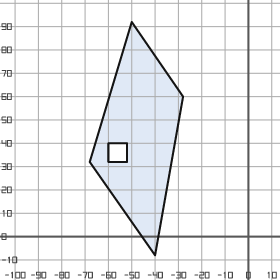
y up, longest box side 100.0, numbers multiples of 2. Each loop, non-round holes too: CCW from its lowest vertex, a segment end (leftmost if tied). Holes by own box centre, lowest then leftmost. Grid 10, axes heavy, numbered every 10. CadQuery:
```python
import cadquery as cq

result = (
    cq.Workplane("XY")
    .moveTo(-40.0, -8.0)
    .lineTo(-28.0, 60.0)
    .lineTo(-50.0, 92.0)
    .lineTo(-68.0, 32.0)
    .close()
    .moveTo(-60.0, 32.0)
    .lineTo(-52.0, 32.0)
    .lineTo(-52.0, 40.0)
    .lineTo(-60.0, 40.0)
    .close()
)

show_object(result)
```